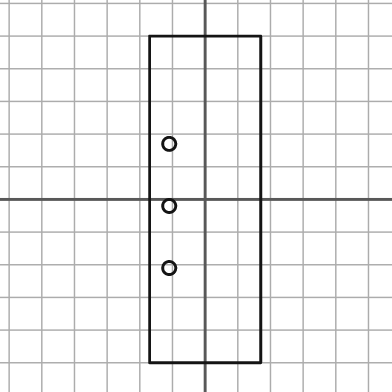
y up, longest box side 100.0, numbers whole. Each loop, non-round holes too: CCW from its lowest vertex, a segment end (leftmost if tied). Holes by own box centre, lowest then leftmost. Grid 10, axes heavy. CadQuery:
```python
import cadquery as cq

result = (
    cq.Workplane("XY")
    .moveTo(-17.0, -50.0)
    .lineTo(17.0, -50.0)
    .lineTo(17.0, 50.0)
    .lineTo(-17.0, 50.0)
    .close()
    .moveTo(-11.0, -21.0)
    .circle(2.0)
    .moveTo(-11.0, -2.0)
    .circle(2.0)
    .moveTo(-11.0, 17.0)
    .circle(2.0)
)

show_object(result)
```